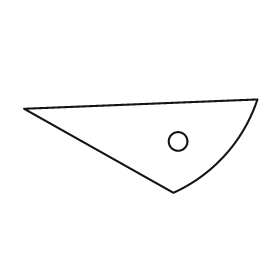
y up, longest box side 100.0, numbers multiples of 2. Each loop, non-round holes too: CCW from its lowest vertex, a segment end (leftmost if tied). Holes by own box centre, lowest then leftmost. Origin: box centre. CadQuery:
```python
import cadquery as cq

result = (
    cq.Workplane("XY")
    .moveTo(14.0, -20.0)
    .threePointArc((36.0, -4.0), (50.0, 20.0))
    .lineTo(-50.0, 16.0)
    .close()
    .moveTo(16.0, 2.0)
    .circle(4.0)
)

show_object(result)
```